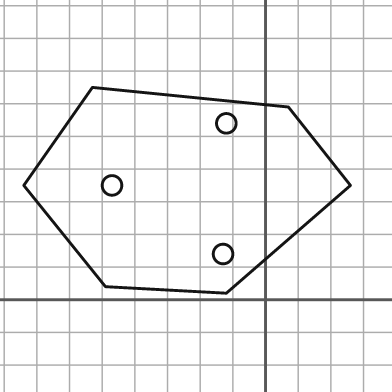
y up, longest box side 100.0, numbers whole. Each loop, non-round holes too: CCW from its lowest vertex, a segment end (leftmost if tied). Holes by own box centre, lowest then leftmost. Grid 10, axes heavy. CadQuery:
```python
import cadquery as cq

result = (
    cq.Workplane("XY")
    .moveTo(-12.0, 2.0)
    .lineTo(26.0, 35.0)
    .lineTo(7.0, 59.0)
    .lineTo(-53.0, 65.0)
    .lineTo(-74.0, 35.0)
    .lineTo(-49.0, 4.0)
    .close()
    .moveTo(-13.0, 14.0)
    .circle(3.0)
    .moveTo(-47.0, 35.0)
    .circle(3.0)
    .moveTo(-12.0, 54.0)
    .circle(3.0)
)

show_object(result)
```